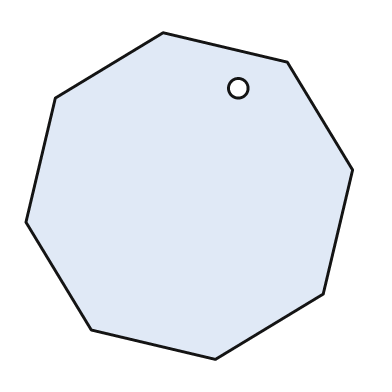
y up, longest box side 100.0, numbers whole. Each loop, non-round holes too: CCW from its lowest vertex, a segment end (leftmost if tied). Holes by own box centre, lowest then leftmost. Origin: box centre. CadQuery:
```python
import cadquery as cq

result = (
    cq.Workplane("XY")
    .moveTo(8.0, -50.0)
    .lineTo(41.0, -30.0)
    .lineTo(50.0, 8.0)
    .lineTo(30.0, 41.0)
    .lineTo(-8.0, 50.0)
    .lineTo(-41.0, 30.0)
    .lineTo(-50.0, -8.0)
    .lineTo(-30.0, -41.0)
    .close()
    .moveTo(15.0, 33.0)
    .circle(3.0)
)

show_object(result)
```